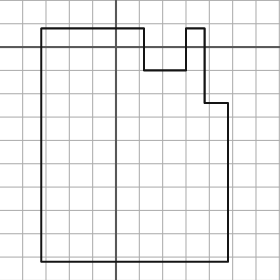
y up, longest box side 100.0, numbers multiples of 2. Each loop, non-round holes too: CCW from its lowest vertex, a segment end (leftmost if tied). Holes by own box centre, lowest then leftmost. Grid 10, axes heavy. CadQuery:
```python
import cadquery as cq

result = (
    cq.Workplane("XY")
    .moveTo(-32.0, -92.0)
    .lineTo(48.0, -92.0)
    .lineTo(48.0, -24.0)
    .lineTo(38.0, -24.0)
    .lineTo(38.0, 8.0)
    .lineTo(30.0, 8.0)
    .lineTo(30.0, -10.0)
    .lineTo(12.0, -10.0)
    .lineTo(12.0, 8.0)
    .lineTo(-32.0, 8.0)
    .close()
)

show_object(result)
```